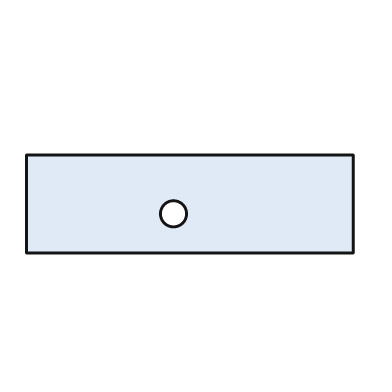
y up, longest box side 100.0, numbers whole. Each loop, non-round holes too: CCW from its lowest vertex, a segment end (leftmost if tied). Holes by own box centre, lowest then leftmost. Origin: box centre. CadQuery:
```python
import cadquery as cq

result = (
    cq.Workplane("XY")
    .moveTo(-50.0, -15.0)
    .lineTo(50.0, -15.0)
    .lineTo(50.0, 15.0)
    .lineTo(-50.0, 15.0)
    .close()
    .moveTo(-5.0, -3.0)
    .circle(4.0)
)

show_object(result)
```